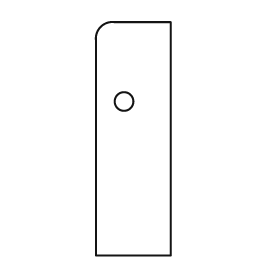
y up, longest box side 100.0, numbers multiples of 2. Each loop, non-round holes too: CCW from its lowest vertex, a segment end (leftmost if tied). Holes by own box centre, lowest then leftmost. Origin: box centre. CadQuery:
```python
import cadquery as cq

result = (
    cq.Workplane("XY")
    .moveTo(-16.0, -50.0)
    .lineTo(16.0, -50.0)
    .lineTo(16.0, 50.0)
    .lineTo(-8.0, 50.0)
    .threePointArc((-14.0, 48.0), (-16.0, 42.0))
    .close()
    .moveTo(-4.0, 16.0)
    .circle(4.0)
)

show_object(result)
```